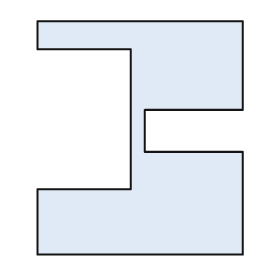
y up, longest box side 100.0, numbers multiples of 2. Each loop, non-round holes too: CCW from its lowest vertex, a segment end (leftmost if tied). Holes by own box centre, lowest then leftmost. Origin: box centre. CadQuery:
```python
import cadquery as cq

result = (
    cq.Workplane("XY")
    .moveTo(-44.0, -50.0)
    .lineTo(44.0, -50.0)
    .lineTo(44.0, -6.0)
    .lineTo(2.0, -6.0)
    .lineTo(2.0, 12.0)
    .lineTo(44.0, 12.0)
    .lineTo(44.0, 50.0)
    .lineTo(-44.0, 50.0)
    .lineTo(-44.0, 38.0)
    .lineTo(-4.0, 38.0)
    .lineTo(-4.0, -22.0)
    .lineTo(-44.0, -22.0)
    .close()
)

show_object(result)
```